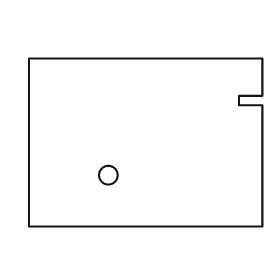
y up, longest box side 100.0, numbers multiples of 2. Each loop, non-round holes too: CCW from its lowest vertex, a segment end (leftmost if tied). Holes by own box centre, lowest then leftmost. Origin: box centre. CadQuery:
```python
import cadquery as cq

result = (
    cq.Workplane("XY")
    .moveTo(-50.0, -36.0)
    .lineTo(50.0, -36.0)
    .lineTo(50.0, 16.0)
    .lineTo(40.0, 16.0)
    .lineTo(40.0, 20.0)
    .lineTo(50.0, 20.0)
    .lineTo(50.0, 36.0)
    .lineTo(-50.0, 36.0)
    .close()
    .moveTo(-16.0, -14.0)
    .circle(4.0)
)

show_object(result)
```